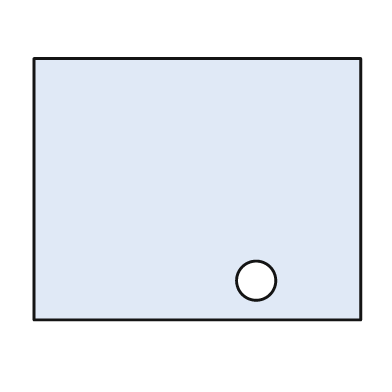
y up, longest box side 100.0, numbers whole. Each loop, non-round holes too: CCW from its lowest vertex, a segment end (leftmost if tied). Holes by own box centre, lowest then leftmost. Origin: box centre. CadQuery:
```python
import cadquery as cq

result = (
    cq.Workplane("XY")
    .moveTo(-50.0, -40.0)
    .lineTo(50.0, -40.0)
    .lineTo(50.0, 40.0)
    .lineTo(-50.0, 40.0)
    .close()
    .moveTo(18.0, -28.0)
    .circle(6.0)
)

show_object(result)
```